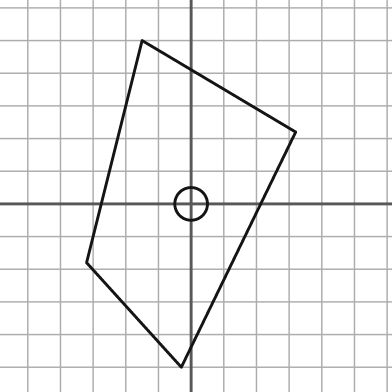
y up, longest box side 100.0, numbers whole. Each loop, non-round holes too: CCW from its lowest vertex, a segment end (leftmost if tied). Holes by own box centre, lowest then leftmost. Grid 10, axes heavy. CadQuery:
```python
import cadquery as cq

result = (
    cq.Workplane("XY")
    .moveTo(-3.0, -50.0)
    .lineTo(32.0, 22.0)
    .lineTo(-15.0, 50.0)
    .lineTo(-32.0, -18.0)
    .close()
    .moveTo(0.0, 0.0)
    .circle(5.0)
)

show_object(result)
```